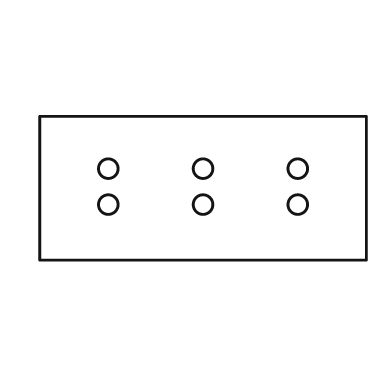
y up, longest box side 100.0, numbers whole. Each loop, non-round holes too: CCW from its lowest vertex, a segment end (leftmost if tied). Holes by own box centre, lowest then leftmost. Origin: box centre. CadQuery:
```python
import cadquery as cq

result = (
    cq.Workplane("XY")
    .moveTo(-50.0, -22.0)
    .lineTo(50.0, -22.0)
    .lineTo(50.0, 22.0)
    .lineTo(-50.0, 22.0)
    .close()
    .moveTo(-29.0, -5.0)
    .circle(3.0)
    .moveTo(0.0, -5.0)
    .circle(3.0)
    .moveTo(29.0, -5.0)
    .circle(3.0)
    .moveTo(-29.0, 6.0)
    .circle(3.0)
    .moveTo(0.0, 6.0)
    .circle(3.0)
    .moveTo(29.0, 6.0)
    .circle(3.0)
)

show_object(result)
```